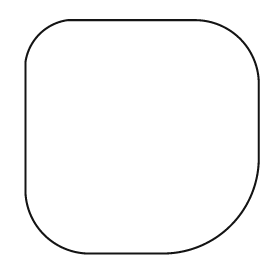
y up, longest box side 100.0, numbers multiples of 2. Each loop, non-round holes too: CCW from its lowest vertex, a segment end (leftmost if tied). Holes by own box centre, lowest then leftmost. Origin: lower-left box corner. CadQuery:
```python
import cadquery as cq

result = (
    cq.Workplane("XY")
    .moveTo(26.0, 0.0)
    .lineTo(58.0, 0.0)
    .threePointArc((88.0, 12.0), (100.0, 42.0))
    .lineTo(100.0, 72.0)
    .threePointArc((92.0, 92.0), (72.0, 100.0))
    .lineTo(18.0, 100.0)
    .threePointArc((6.0, 94.0), (0.0, 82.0))
    .lineTo(0.0, 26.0)
    .threePointArc((8.0, 8.0), (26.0, 0.0))
    .close()
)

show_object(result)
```